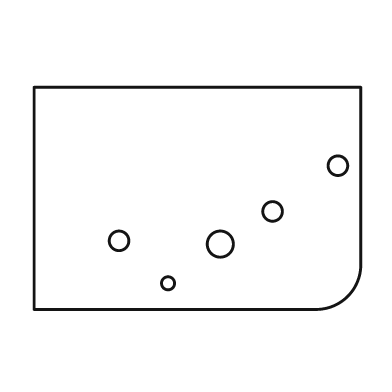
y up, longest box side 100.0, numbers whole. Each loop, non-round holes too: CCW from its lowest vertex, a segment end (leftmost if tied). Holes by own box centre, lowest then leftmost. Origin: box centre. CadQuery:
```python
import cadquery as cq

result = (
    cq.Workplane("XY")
    .moveTo(-50.0, -34.0)
    .lineTo(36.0, -34.0)
    .threePointArc((46.0, -30.0), (50.0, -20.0))
    .lineTo(50.0, 34.0)
    .lineTo(-50.0, 34.0)
    .close()
    .moveTo(-9.0, -26.0)
    .circle(2.0)
    .moveTo(7.0, -14.0)
    .circle(4.0)
    .moveTo(-24.0, -13.0)
    .circle(3.0)
    .moveTo(23.0, -4.0)
    .circle(3.0)
    .moveTo(43.0, 10.0)
    .circle(3.0)
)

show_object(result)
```